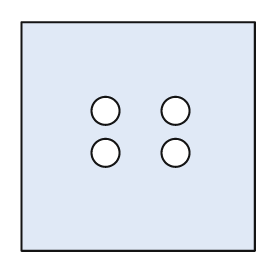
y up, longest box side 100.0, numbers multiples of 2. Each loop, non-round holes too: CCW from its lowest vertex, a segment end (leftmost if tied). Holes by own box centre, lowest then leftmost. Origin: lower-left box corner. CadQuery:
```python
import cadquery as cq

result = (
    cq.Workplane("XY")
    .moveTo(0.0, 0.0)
    .lineTo(100.0, 0.0)
    .lineTo(100.0, 98.0)
    .lineTo(0.0, 98.0)
    .close()
    .moveTo(36.0, 42.0)
    .circle(6.0)
    .moveTo(66.0, 42.0)
    .circle(6.0)
    .moveTo(36.0, 60.0)
    .circle(6.0)
    .moveTo(66.0, 60.0)
    .circle(6.0)
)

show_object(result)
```